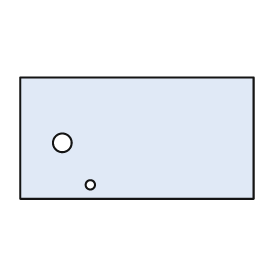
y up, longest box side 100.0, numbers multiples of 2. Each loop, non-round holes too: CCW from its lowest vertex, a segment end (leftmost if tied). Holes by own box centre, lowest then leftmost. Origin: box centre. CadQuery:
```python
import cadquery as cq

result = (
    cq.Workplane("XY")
    .moveTo(-50.0, -26.0)
    .lineTo(50.0, -26.0)
    .lineTo(50.0, 26.0)
    .lineTo(-50.0, 26.0)
    .close()
    .moveTo(-20.0, -20.0)
    .circle(2.0)
    .moveTo(-32.0, -2.0)
    .circle(4.0)
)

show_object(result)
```